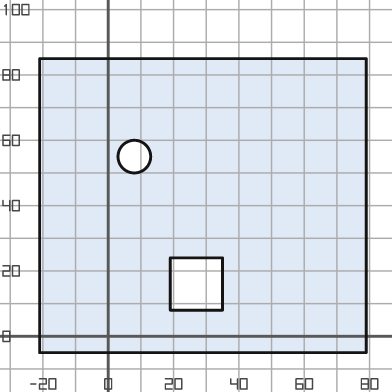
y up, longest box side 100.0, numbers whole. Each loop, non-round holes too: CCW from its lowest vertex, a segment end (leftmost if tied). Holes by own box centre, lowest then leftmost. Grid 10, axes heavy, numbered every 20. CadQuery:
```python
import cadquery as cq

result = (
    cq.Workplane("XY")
    .moveTo(-21.0, -5.0)
    .lineTo(79.0, -5.0)
    .lineTo(79.0, 85.0)
    .lineTo(-21.0, 85.0)
    .close()
    .moveTo(19.0, 8.0)
    .lineTo(35.0, 8.0)
    .lineTo(35.0, 24.0)
    .lineTo(19.0, 24.0)
    .close()
    .moveTo(8.0, 55.0)
    .circle(5.0)
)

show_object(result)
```